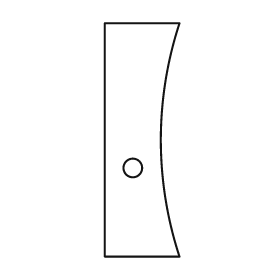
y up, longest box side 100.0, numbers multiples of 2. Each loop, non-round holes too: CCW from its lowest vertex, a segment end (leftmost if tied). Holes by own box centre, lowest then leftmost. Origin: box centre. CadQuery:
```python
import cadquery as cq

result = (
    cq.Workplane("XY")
    .moveTo(-16.0, -50.0)
    .lineTo(16.0, -50.0)
    .threePointArc((8.0, 0.0), (16.0, 50.0))
    .lineTo(-16.0, 50.0)
    .close()
    .moveTo(-4.0, -12.0)
    .circle(4.0)
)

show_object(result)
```